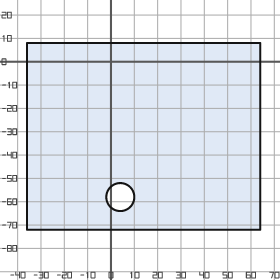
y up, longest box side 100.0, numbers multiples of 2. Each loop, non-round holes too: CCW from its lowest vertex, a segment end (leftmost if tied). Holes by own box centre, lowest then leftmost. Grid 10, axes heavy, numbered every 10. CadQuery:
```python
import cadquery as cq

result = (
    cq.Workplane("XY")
    .moveTo(-36.0, -72.0)
    .lineTo(64.0, -72.0)
    .lineTo(64.0, 8.0)
    .lineTo(-36.0, 8.0)
    .close()
    .moveTo(4.0, -58.0)
    .circle(6.0)
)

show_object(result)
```